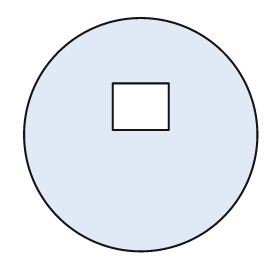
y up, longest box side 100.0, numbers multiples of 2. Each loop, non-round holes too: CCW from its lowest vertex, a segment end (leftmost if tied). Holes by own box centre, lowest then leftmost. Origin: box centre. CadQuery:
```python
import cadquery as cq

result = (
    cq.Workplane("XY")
    .moveTo(0.0, 0.0)
    .circle(50.0)
    .moveTo(-12.0, 2.0)
    .lineTo(12.0, 2.0)
    .lineTo(12.0, 22.0)
    .lineTo(-12.0, 22.0)
    .close()
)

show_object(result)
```